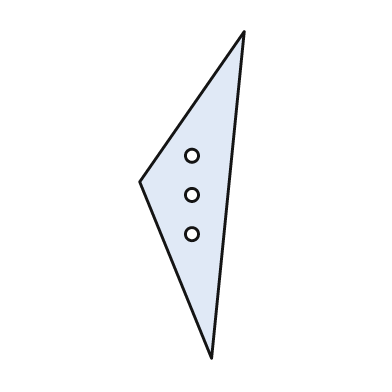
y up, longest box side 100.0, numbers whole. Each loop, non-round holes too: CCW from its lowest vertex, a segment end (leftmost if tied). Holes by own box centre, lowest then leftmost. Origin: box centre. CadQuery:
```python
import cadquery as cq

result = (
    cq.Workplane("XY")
    .moveTo(6.0, -50.0)
    .lineTo(16.0, 50.0)
    .lineTo(-16.0, 4.0)
    .close()
    .moveTo(0.0, -12.0)
    .circle(2.0)
    .moveTo(0.0, 0.0)
    .circle(2.0)
    .moveTo(0.0, 12.0)
    .circle(2.0)
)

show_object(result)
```